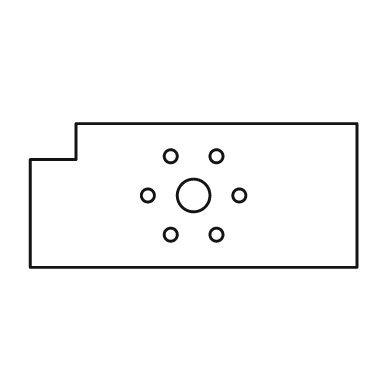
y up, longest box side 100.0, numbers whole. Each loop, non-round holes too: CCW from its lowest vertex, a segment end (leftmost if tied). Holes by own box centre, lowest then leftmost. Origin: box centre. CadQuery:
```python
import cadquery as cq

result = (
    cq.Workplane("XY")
    .moveTo(-50.0, -22.0)
    .lineTo(50.0, -22.0)
    .lineTo(50.0, 22.0)
    .lineTo(-36.0, 22.0)
    .lineTo(-36.0, 11.0)
    .lineTo(-50.0, 11.0)
    .close()
    .moveTo(-7.0, -12.0)
    .circle(2.0)
    .moveTo(7.0, -12.0)
    .circle(2.0)
    .moveTo(-14.0, 0.0)
    .circle(2.0)
    .moveTo(0.0, 0.0)
    .circle(5.0)
    .moveTo(14.0, 0.0)
    .circle(2.0)
    .moveTo(-7.0, 12.0)
    .circle(2.0)
    .moveTo(7.0, 12.0)
    .circle(2.0)
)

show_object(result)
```